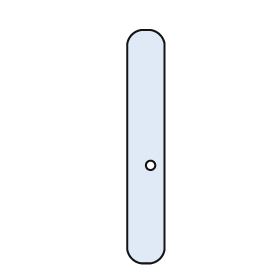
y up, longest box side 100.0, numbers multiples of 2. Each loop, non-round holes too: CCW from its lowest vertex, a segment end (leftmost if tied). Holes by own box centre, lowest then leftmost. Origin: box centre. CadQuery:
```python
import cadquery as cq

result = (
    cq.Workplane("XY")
    .moveTo(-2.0, -50.0)
    .lineTo(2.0, -50.0)
    .threePointArc((6.0, -48.0), (8.0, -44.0))
    .lineTo(8.0, 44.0)
    .threePointArc((6.0, 48.0), (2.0, 50.0))
    .lineTo(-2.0, 50.0)
    .threePointArc((-6.0, 48.0), (-8.0, 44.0))
    .lineTo(-8.0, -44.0)
    .threePointArc((-6.0, -48.0), (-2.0, -50.0))
    .close()
    .moveTo(2.0, -8.0)
    .circle(2.0)
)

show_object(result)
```